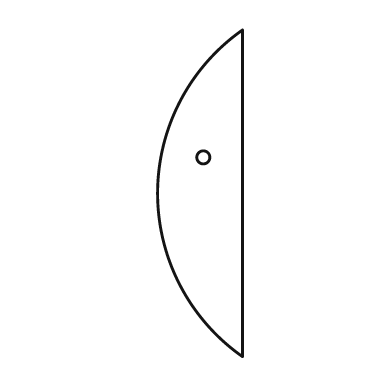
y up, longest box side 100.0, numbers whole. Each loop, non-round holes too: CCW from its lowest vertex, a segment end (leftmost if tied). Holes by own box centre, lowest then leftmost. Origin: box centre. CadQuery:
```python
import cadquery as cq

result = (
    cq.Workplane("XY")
    .moveTo(13.0, -50.0)
    .lineTo(13.0, 50.0)
    .threePointArc((-13.0, 0.0), (13.0, -50.0))
    .close()
    .moveTo(1.0, 11.0)
    .circle(2.0)
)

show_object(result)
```